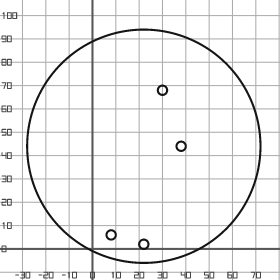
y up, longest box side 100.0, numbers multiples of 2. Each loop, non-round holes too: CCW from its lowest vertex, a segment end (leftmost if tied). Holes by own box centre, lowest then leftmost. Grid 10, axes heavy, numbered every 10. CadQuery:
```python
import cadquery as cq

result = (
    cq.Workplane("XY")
    .moveTo(22.0, 44.0)
    .circle(50.0)
    .moveTo(22.0, 2.0)
    .circle(2.0)
    .moveTo(8.0, 6.0)
    .circle(2.0)
    .moveTo(38.0, 44.0)
    .circle(2.0)
    .moveTo(30.0, 68.0)
    .circle(2.0)
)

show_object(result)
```